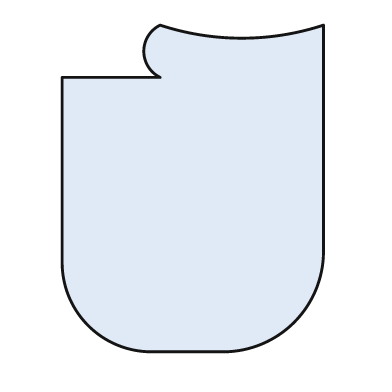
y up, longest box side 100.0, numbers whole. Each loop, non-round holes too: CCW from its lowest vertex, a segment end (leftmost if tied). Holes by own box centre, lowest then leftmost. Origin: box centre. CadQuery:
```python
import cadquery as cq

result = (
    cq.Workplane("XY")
    .moveTo(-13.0, -50.0)
    .lineTo(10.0, -50.0)
    .threePointArc((31.0, -41.0), (40.0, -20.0))
    .lineTo(40.0, 50.0)
    .threePointArc((15.0, 46.0), (-10.0, 50.0))
    .threePointArc((-15.0, 42.0), (-10.0, 34.0))
    .lineTo(-40.0, 34.0)
    .lineTo(-40.0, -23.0)
    .threePointArc((-32.0, -42.0), (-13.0, -50.0))
    .close()
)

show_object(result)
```